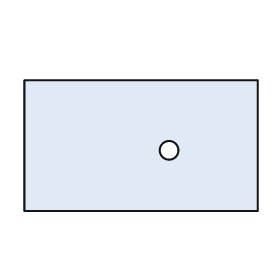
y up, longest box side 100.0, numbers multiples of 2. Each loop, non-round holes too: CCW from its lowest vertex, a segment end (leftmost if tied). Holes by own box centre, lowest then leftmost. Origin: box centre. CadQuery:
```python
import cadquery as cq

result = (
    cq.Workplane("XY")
    .moveTo(-50.0, -28.0)
    .lineTo(50.0, -28.0)
    .lineTo(50.0, 28.0)
    .lineTo(-50.0, 28.0)
    .close()
    .moveTo(12.0, -2.0)
    .circle(4.0)
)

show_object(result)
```